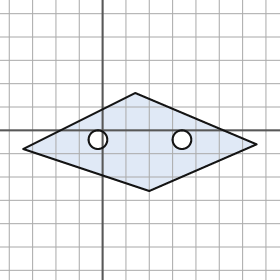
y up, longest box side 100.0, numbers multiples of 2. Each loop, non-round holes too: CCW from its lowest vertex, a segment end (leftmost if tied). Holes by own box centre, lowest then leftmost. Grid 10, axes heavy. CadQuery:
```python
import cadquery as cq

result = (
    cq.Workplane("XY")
    .moveTo(20.0, -26.0)
    .lineTo(66.0, -6.0)
    .lineTo(14.0, 16.0)
    .lineTo(-34.0, -8.0)
    .close()
    .moveTo(-2.0, -4.0)
    .circle(4.0)
    .moveTo(34.0, -4.0)
    .circle(4.0)
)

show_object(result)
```